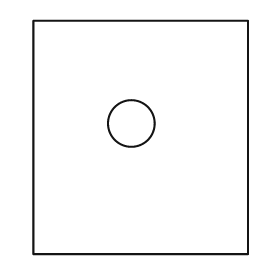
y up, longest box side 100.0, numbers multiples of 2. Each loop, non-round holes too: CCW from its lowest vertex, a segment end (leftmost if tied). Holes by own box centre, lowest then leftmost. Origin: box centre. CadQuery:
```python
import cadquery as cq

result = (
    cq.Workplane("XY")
    .moveTo(-46.0, -50.0)
    .lineTo(46.0, -50.0)
    .lineTo(46.0, 50.0)
    .lineTo(-46.0, 50.0)
    .close()
    .moveTo(-4.0, 6.0)
    .circle(10.0)
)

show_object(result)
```